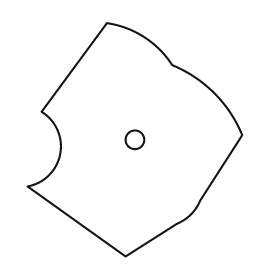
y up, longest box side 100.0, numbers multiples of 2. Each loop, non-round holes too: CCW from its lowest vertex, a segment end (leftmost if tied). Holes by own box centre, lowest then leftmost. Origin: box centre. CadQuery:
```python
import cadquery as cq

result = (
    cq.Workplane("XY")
    .moveTo(-4.0, -50.0)
    .lineTo(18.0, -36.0)
    .threePointArc((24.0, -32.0), (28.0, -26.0))
    .lineTo(46.0, 2.0)
    .threePointArc((34.0, 20.0), (16.0, 32.0))
    .threePointArc((4.0, 44.0), (-12.0, 50.0))
    .lineTo(-40.0, 12.0)
    .threePointArc((-32.0, -6.0), (-46.0, -20.0))
    .close()
    .moveTo(0.0, 0.0)
    .circle(4.0)
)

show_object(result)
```